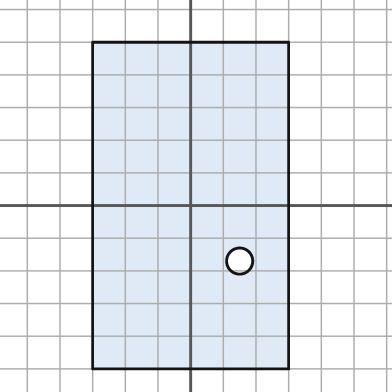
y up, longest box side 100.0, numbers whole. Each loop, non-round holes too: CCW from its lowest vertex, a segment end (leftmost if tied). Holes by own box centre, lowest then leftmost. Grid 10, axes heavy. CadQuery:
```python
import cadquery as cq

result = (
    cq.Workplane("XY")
    .moveTo(-30.0, -50.0)
    .lineTo(30.0, -50.0)
    .lineTo(30.0, 50.0)
    .lineTo(-30.0, 50.0)
    .close()
    .moveTo(15.0, -17.0)
    .circle(4.0)
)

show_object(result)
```